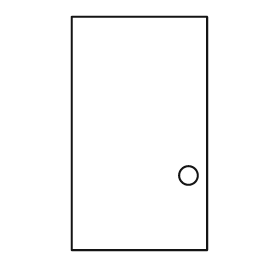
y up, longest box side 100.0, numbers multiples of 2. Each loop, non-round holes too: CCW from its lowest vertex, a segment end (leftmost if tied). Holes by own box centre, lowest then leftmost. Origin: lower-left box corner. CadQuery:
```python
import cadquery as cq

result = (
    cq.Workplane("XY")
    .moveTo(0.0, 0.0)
    .lineTo(58.0, 0.0)
    .lineTo(58.0, 100.0)
    .lineTo(0.0, 100.0)
    .close()
    .moveTo(50.0, 32.0)
    .circle(4.0)
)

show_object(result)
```